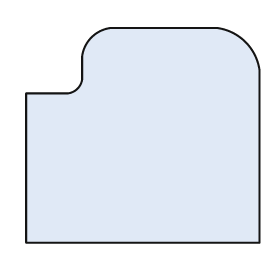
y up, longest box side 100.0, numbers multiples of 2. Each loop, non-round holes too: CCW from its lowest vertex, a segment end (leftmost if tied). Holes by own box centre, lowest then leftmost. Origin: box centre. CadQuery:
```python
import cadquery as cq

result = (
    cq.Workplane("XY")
    .moveTo(-50.0, -46.0)
    .lineTo(50.0, -46.0)
    .lineTo(50.0, 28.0)
    .threePointArc((44.0, 40.0), (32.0, 46.0))
    .lineTo(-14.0, 46.0)
    .threePointArc((-22.0, 42.0), (-26.0, 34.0))
    .lineTo(-26.0, 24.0)
    .threePointArc((-28.0, 20.0), (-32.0, 18.0))
    .lineTo(-50.0, 18.0)
    .close()
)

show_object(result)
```